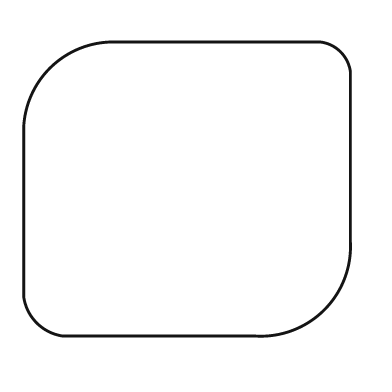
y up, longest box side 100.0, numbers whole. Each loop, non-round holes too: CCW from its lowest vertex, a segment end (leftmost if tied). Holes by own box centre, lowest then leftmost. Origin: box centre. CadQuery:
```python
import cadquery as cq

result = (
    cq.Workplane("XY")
    .moveTo(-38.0, -45.0)
    .lineTo(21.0, -45.0)
    .threePointArc((42.0, -37.0), (50.0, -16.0))
    .lineTo(50.0, 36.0)
    .threePointArc((47.0, 42.0), (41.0, 45.0))
    .lineTo(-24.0, 45.0)
    .threePointArc((-42.0, 37.0), (-50.0, 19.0))
    .lineTo(-50.0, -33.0)
    .threePointArc((-46.0, -41.0), (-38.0, -45.0))
    .close()
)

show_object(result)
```